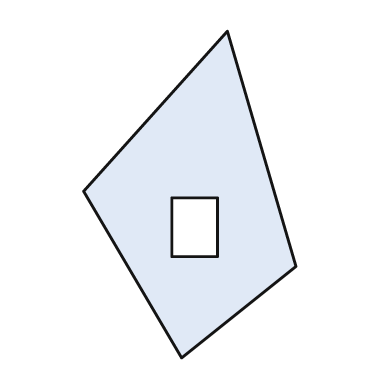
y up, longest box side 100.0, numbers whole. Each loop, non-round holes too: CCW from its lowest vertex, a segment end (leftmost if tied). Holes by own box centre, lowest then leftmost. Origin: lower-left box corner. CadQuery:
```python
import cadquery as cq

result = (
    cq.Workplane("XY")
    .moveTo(30.0, 0.0)
    .lineTo(65.0, 28.0)
    .lineTo(44.0, 100.0)
    .lineTo(0.0, 51.0)
    .close()
    .moveTo(27.0, 31.0)
    .lineTo(41.0, 31.0)
    .lineTo(41.0, 49.0)
    .lineTo(27.0, 49.0)
    .close()
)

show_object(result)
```